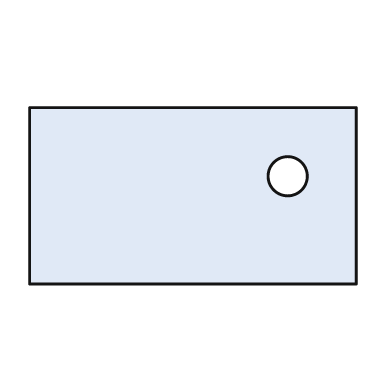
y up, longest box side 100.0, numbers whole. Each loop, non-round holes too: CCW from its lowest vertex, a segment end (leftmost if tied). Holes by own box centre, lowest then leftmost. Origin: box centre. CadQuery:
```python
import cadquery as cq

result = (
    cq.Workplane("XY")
    .moveTo(-50.0, -27.0)
    .lineTo(50.0, -27.0)
    .lineTo(50.0, 27.0)
    .lineTo(-50.0, 27.0)
    .close()
    .moveTo(29.0, 6.0)
    .circle(6.0)
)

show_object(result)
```